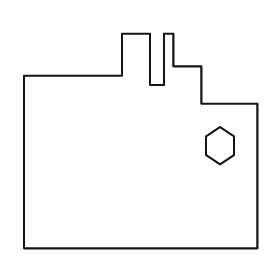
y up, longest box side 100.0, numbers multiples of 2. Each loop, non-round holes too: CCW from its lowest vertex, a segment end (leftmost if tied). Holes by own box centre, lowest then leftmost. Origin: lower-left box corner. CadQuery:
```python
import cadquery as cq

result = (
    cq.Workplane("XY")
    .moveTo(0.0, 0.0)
    .lineTo(100.0, 0.0)
    .lineTo(100.0, 62.0)
    .lineTo(76.0, 62.0)
    .lineTo(76.0, 78.0)
    .lineTo(64.0, 78.0)
    .lineTo(64.0, 92.0)
    .lineTo(60.0, 92.0)
    .lineTo(60.0, 70.0)
    .lineTo(54.0, 70.0)
    .lineTo(54.0, 92.0)
    .lineTo(42.0, 92.0)
    .lineTo(42.0, 74.0)
    .lineTo(0.0, 74.0)
    .close()
    .moveTo(84.0, 36.0)
    .lineTo(90.0, 40.0)
    .lineTo(90.0, 48.0)
    .lineTo(84.0, 52.0)
    .lineTo(78.0, 48.0)
    .lineTo(78.0, 40.0)
    .close()
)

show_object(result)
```